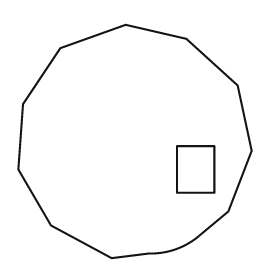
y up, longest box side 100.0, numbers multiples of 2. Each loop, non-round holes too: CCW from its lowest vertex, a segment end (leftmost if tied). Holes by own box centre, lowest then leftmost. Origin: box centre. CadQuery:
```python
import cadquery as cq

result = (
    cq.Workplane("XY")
    .moveTo(-10.0, -50.0)
    .lineTo(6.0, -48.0)
    .threePointArc((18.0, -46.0), (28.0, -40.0))
    .lineTo(40.0, -30.0)
    .lineTo(50.0, -4.0)
    .lineTo(44.0, 24.0)
    .lineTo(22.0, 44.0)
    .lineTo(-4.0, 50.0)
    .lineTo(-32.0, 40.0)
    .lineTo(-48.0, 16.0)
    .lineTo(-50.0, -12.0)
    .lineTo(-36.0, -36.0)
    .close()
    .moveTo(18.0, -22.0)
    .lineTo(34.0, -22.0)
    .lineTo(34.0, -2.0)
    .lineTo(18.0, -2.0)
    .close()
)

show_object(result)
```